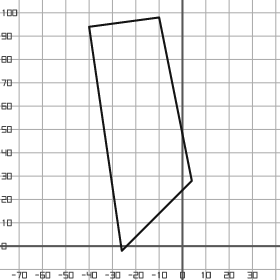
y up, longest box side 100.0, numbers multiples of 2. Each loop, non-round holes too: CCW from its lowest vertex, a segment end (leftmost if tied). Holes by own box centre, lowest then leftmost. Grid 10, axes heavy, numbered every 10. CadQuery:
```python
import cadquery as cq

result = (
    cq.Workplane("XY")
    .moveTo(-26.0, -2.0)
    .lineTo(4.0, 28.0)
    .lineTo(-10.0, 98.0)
    .lineTo(-40.0, 94.0)
    .close()
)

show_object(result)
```